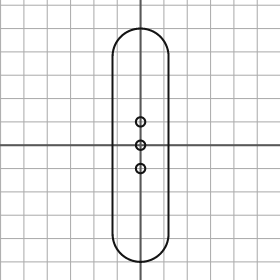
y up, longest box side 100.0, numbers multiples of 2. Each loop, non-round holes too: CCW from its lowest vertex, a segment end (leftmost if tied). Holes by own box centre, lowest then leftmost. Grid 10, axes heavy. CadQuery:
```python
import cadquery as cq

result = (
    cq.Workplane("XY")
    .moveTo(-12.0, -38.0)
    .threePointArc((0.0, -50.0), (12.0, -38.0))
    .lineTo(12.0, 38.0)
    .threePointArc((0.0, 50.0), (-12.0, 38.0))
    .close()
    .moveTo(0.0, -10.0)
    .circle(2.0)
    .moveTo(0.0, 0.0)
    .circle(2.0)
    .moveTo(0.0, 10.0)
    .circle(2.0)
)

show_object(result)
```